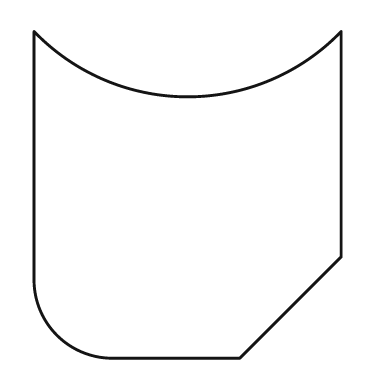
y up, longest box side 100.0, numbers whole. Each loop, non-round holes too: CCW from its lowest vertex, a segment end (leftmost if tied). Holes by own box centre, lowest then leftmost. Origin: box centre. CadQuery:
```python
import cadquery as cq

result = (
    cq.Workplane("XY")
    .moveTo(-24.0, -50.0)
    .lineTo(16.0, -50.0)
    .lineTo(47.0, -19.0)
    .lineTo(47.0, 50.0)
    .threePointArc((0.0, 30.0), (-47.0, 50.0))
    .lineTo(-47.0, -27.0)
    .threePointArc((-40.0, -43.0), (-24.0, -50.0))
    .close()
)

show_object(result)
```